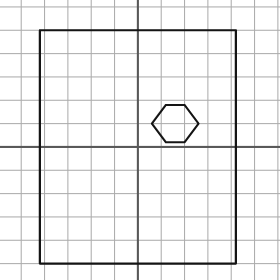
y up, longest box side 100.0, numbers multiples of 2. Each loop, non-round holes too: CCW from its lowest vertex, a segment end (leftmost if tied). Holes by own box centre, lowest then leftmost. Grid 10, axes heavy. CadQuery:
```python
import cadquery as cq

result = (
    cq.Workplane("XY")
    .moveTo(-42.0, -50.0)
    .lineTo(42.0, -50.0)
    .lineTo(42.0, 50.0)
    .lineTo(-42.0, 50.0)
    .close()
    .moveTo(12.0, 2.0)
    .lineTo(20.0, 2.0)
    .lineTo(26.0, 10.0)
    .lineTo(20.0, 18.0)
    .lineTo(12.0, 18.0)
    .lineTo(6.0, 10.0)
    .close()
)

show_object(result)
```